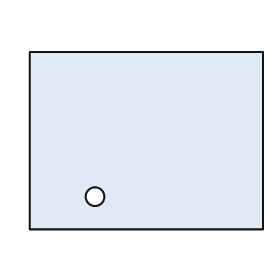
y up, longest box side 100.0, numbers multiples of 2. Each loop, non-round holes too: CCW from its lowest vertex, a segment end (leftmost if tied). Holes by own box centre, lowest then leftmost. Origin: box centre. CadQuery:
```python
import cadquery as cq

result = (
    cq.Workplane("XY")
    .moveTo(-50.0, -38.0)
    .lineTo(50.0, -38.0)
    .lineTo(50.0, 38.0)
    .lineTo(-50.0, 38.0)
    .close()
    .moveTo(-22.0, -24.0)
    .circle(4.0)
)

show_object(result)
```